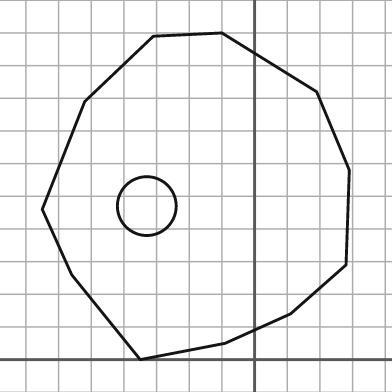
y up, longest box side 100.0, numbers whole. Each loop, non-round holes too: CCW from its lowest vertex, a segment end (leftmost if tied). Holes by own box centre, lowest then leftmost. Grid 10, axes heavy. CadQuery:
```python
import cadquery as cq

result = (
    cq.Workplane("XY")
    .moveTo(-35.0, 0.0)
    .lineTo(-9.0, 5.0)
    .lineTo(11.0, 14.0)
    .lineTo(28.0, 29.0)
    .lineTo(29.0, 58.0)
    .lineTo(19.0, 82.0)
    .lineTo(-10.0, 100.0)
    .lineTo(-31.0, 99.0)
    .lineTo(-52.0, 79.0)
    .lineTo(-65.0, 46.0)
    .lineTo(-56.0, 26.0)
    .close()
    .moveTo(-33.0, 47.0)
    .circle(9.0)
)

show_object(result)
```